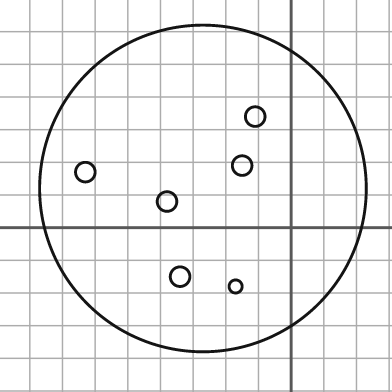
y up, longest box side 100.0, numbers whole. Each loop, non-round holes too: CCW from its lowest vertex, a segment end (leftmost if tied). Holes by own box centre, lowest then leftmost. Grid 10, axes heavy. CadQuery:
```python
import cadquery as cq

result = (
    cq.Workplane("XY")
    .moveTo(-27.0, 12.0)
    .circle(50.0)
    .moveTo(-17.0, -18.0)
    .circle(2.0)
    .moveTo(-34.0, -15.0)
    .circle(3.0)
    .moveTo(-38.0, 8.0)
    .circle(3.0)
    .moveTo(-63.0, 17.0)
    .circle(3.0)
    .moveTo(-15.0, 19.0)
    .circle(3.0)
    .moveTo(-11.0, 34.0)
    .circle(3.0)
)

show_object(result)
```